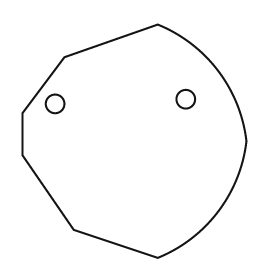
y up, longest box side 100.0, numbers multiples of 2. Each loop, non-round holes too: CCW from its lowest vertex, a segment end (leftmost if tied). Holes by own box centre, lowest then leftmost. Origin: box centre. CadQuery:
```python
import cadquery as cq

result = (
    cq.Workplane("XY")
    .moveTo(10.0, -50.0)
    .threePointArc((36.0, -30.0), (48.0, 0.0))
    .threePointArc((36.0, 30.0), (10.0, 50.0))
    .lineTo(-30.0, 36.0)
    .lineTo(-48.0, 12.0)
    .lineTo(-48.0, -6.0)
    .lineTo(-26.0, -38.0)
    .close()
    .moveTo(-34.0, 16.0)
    .circle(4.0)
    .moveTo(22.0, 18.0)
    .circle(4.0)
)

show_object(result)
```